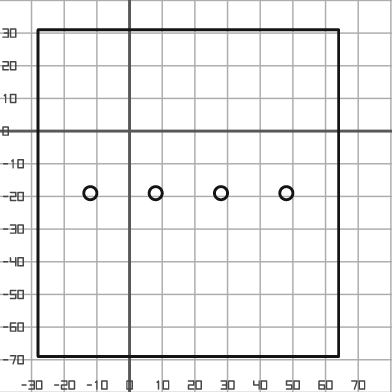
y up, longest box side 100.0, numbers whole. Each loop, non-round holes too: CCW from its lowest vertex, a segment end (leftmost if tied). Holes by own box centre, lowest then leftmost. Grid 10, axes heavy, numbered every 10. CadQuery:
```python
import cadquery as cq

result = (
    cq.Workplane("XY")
    .moveTo(-28.0, -69.0)
    .lineTo(64.0, -69.0)
    .lineTo(64.0, 31.0)
    .lineTo(-28.0, 31.0)
    .close()
    .moveTo(-12.0, -19.0)
    .circle(2.0)
    .moveTo(8.0, -19.0)
    .circle(2.0)
    .moveTo(28.0, -19.0)
    .circle(2.0)
    .moveTo(48.0, -19.0)
    .circle(2.0)
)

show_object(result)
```